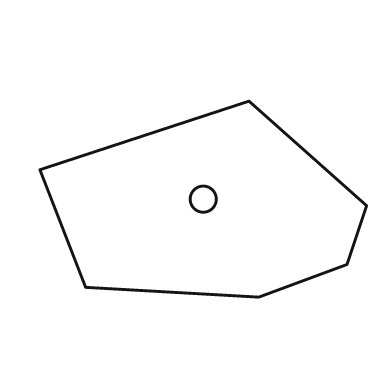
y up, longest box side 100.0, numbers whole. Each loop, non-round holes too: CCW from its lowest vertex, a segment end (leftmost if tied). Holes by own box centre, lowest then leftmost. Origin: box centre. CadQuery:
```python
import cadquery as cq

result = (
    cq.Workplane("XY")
    .moveTo(17.0, -30.0)
    .lineTo(44.0, -20.0)
    .lineTo(50.0, -2.0)
    .lineTo(14.0, 30.0)
    .lineTo(-50.0, 9.0)
    .lineTo(-36.0, -27.0)
    .close()
    .moveTo(0.0, 0.0)
    .circle(4.0)
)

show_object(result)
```